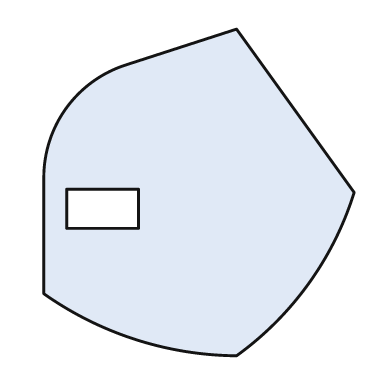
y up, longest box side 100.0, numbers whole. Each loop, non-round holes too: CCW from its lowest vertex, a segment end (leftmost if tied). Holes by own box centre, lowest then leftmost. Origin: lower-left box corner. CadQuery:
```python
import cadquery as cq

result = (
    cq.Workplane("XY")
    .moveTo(59.0, 0.0)
    .threePointArc((81.0, 22.0), (95.0, 50.0))
    .lineTo(59.0, 100.0)
    .lineTo(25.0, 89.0)
    .threePointArc((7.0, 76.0), (0.0, 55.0))
    .lineTo(0.0, 19.0)
    .threePointArc((28.0, 5.0), (59.0, 0.0))
    .close()
    .moveTo(7.0, 39.0)
    .lineTo(29.0, 39.0)
    .lineTo(29.0, 51.0)
    .lineTo(7.0, 51.0)
    .close()
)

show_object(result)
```